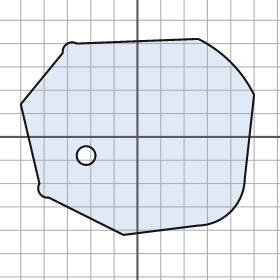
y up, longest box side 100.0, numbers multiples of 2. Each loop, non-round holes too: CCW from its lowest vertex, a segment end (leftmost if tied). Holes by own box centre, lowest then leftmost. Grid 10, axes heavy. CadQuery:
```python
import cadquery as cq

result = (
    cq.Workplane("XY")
    .moveTo(-6.0, -42.0)
    .lineTo(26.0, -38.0)
    .threePointArc((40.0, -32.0), (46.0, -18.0))
    .lineTo(50.0, 18.0)
    .threePointArc((40.0, 32.0), (26.0, 42.0))
    .lineTo(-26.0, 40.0)
    .threePointArc((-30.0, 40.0), (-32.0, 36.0))
    .lineTo(-50.0, 14.0)
    .lineTo(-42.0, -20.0)
    .threePointArc((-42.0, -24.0), (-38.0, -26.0))
    .close()
    .moveTo(-22.0, -8.0)
    .circle(4.0)
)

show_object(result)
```